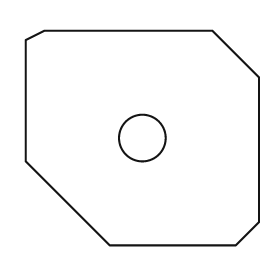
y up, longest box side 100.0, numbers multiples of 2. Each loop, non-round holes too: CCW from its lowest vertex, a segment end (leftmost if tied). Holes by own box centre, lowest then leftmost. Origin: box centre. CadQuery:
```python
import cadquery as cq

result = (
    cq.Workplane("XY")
    .moveTo(-14.0, -46.0)
    .lineTo(40.0, -46.0)
    .lineTo(50.0, -36.0)
    .lineTo(50.0, 26.0)
    .lineTo(30.0, 46.0)
    .lineTo(-42.0, 46.0)
    .lineTo(-50.0, 42.0)
    .lineTo(-50.0, -10.0)
    .close()
    .moveTo(0.0, 0.0)
    .circle(10.0)
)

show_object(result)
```